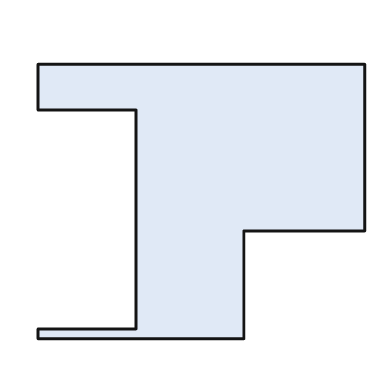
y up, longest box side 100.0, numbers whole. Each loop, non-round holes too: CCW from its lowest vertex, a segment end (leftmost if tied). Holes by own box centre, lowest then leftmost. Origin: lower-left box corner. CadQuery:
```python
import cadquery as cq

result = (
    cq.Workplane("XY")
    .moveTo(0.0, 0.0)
    .lineTo(63.0, 0.0)
    .lineTo(63.0, 33.0)
    .lineTo(100.0, 33.0)
    .lineTo(100.0, 84.0)
    .lineTo(0.0, 84.0)
    .lineTo(0.0, 70.0)
    .lineTo(30.0, 70.0)
    .lineTo(30.0, 3.0)
    .lineTo(0.0, 3.0)
    .close()
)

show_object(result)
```